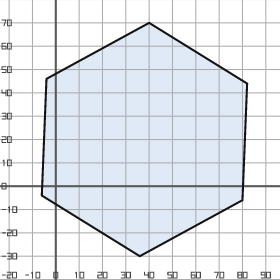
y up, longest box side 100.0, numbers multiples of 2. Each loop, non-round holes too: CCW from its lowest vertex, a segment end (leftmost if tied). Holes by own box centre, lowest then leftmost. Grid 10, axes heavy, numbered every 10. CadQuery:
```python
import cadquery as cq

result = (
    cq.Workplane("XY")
    .moveTo(36.0, -30.0)
    .lineTo(80.0, -6.0)
    .lineTo(82.0, 44.0)
    .lineTo(40.0, 70.0)
    .lineTo(-4.0, 46.0)
    .lineTo(-6.0, -4.0)
    .close()
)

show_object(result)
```